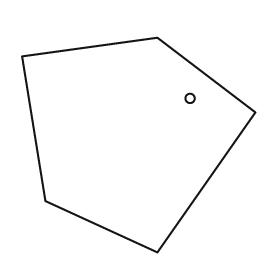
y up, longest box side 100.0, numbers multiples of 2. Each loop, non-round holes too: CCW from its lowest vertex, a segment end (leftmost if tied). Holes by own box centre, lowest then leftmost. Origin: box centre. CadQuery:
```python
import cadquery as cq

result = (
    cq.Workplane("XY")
    .moveTo(8.0, -46.0)
    .lineTo(50.0, 14.0)
    .lineTo(8.0, 46.0)
    .lineTo(-50.0, 38.0)
    .lineTo(-40.0, -24.0)
    .close()
    .moveTo(22.0, 20.0)
    .circle(2.0)
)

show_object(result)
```